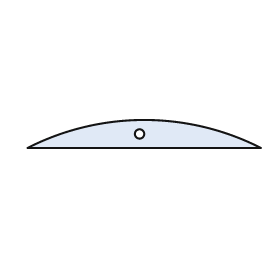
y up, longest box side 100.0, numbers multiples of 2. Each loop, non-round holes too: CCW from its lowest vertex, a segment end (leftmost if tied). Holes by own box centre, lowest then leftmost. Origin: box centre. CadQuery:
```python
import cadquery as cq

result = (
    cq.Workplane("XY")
    .moveTo(-50.0, -6.0)
    .lineTo(50.0, -6.0)
    .threePointArc((0.0, 6.0), (-50.0, -6.0))
    .close()
    .moveTo(-2.0, 0.0)
    .circle(2.0)
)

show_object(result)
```